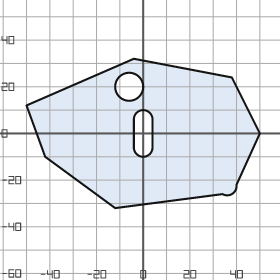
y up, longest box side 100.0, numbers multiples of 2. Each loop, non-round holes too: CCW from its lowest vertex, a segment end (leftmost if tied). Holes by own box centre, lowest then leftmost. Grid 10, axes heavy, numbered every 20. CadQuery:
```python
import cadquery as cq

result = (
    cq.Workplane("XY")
    .moveTo(-12.0, -32.0)
    .lineTo(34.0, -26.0)
    .threePointArc((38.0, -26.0), (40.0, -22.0))
    .lineTo(50.0, 0.0)
    .lineTo(38.0, 24.0)
    .lineTo(-4.0, 32.0)
    .lineTo(-50.0, 12.0)
    .lineTo(-42.0, -10.0)
    .close()
    .moveTo(-4.0, -6.0)
    .threePointArc((0.0, -10.0), (4.0, -6.0))
    .lineTo(4.0, 6.0)
    .threePointArc((0.0, 10.0), (-4.0, 6.0))
    .close()
    .moveTo(-6.0, 20.0)
    .circle(6.0)
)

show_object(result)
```